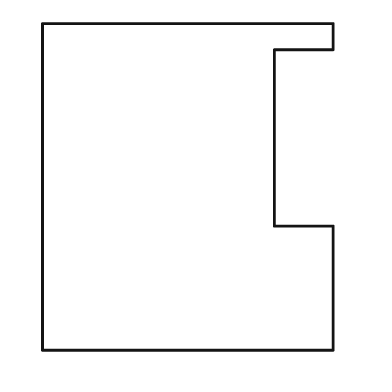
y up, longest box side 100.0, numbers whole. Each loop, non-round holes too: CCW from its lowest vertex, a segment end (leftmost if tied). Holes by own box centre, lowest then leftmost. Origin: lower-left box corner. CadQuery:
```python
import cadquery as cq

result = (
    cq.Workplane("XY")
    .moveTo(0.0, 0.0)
    .lineTo(89.0, 0.0)
    .lineTo(89.0, 38.0)
    .lineTo(71.0, 38.0)
    .lineTo(71.0, 92.0)
    .lineTo(89.0, 92.0)
    .lineTo(89.0, 100.0)
    .lineTo(0.0, 100.0)
    .close()
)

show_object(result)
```